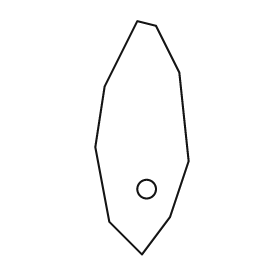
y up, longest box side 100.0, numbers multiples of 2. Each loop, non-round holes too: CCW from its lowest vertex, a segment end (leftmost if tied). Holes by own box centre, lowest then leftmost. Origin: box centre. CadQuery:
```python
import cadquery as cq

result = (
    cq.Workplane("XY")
    .moveTo(0.0, -50.0)
    .lineTo(12.0, -34.0)
    .lineTo(20.0, -10.0)
    .lineTo(16.0, 28.0)
    .lineTo(6.0, 48.0)
    .lineTo(-2.0, 50.0)
    .lineTo(-16.0, 22.0)
    .lineTo(-20.0, -4.0)
    .lineTo(-14.0, -36.0)
    .close()
    .moveTo(2.0, -22.0)
    .circle(4.0)
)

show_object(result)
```